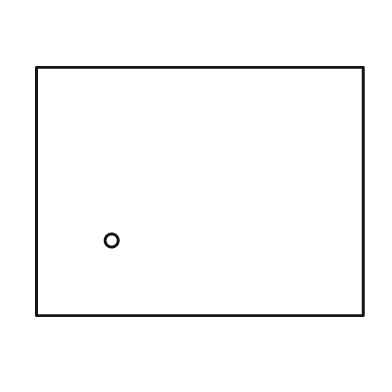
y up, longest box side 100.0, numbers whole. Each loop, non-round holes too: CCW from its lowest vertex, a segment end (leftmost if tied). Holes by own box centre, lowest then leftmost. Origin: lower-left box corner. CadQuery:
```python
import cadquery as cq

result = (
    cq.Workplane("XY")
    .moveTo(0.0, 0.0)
    .lineTo(100.0, 0.0)
    .lineTo(100.0, 76.0)
    .lineTo(0.0, 76.0)
    .close()
    .moveTo(23.0, 23.0)
    .circle(2.0)
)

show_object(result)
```